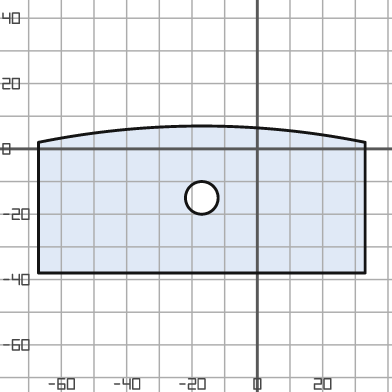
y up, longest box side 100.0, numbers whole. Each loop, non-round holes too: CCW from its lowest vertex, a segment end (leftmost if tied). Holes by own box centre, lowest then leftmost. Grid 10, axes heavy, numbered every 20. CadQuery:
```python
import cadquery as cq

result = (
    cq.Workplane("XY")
    .moveTo(-67.0, -38.0)
    .lineTo(33.0, -38.0)
    .lineTo(33.0, 2.0)
    .threePointArc((-17.0, 7.0), (-67.0, 2.0))
    .close()
    .moveTo(-17.0, -15.0)
    .circle(5.0)
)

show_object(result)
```